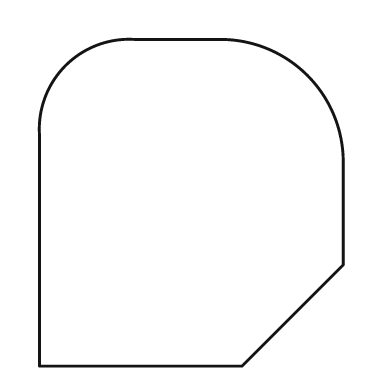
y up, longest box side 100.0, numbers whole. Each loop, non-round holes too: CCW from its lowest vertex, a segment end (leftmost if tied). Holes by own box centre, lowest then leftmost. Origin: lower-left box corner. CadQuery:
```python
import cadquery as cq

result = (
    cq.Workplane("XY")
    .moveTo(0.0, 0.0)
    .lineTo(62.0, 0.0)
    .lineTo(93.0, 31.0)
    .lineTo(93.0, 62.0)
    .threePointArc((82.0, 89.0), (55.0, 100.0))
    .lineTo(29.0, 100.0)
    .threePointArc((8.0, 92.0), (0.0, 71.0))
    .close()
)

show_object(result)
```